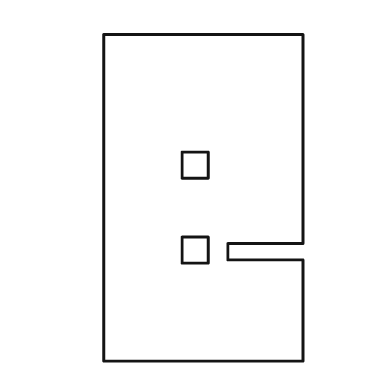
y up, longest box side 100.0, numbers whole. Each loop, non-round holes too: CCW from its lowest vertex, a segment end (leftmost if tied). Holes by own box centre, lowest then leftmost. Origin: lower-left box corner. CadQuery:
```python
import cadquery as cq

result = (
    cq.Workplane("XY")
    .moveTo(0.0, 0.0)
    .lineTo(61.0, 0.0)
    .lineTo(61.0, 31.0)
    .lineTo(38.0, 31.0)
    .lineTo(38.0, 36.0)
    .lineTo(61.0, 36.0)
    .lineTo(61.0, 100.0)
    .lineTo(0.0, 100.0)
    .close()
    .moveTo(24.0, 30.0)
    .lineTo(32.0, 30.0)
    .lineTo(32.0, 38.0)
    .lineTo(24.0, 38.0)
    .close()
    .moveTo(24.0, 56.0)
    .lineTo(32.0, 56.0)
    .lineTo(32.0, 64.0)
    .lineTo(24.0, 64.0)
    .close()
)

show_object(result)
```